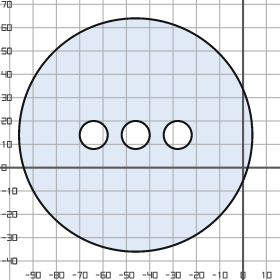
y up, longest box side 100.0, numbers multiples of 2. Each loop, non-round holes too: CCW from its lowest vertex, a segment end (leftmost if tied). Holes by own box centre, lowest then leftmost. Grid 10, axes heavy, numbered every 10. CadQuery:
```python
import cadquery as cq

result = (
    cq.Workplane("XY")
    .moveTo(-46.0, 14.0)
    .circle(50.0)
    .moveTo(-64.0, 14.0)
    .circle(6.0)
    .moveTo(-46.0, 14.0)
    .circle(6.0)
    .moveTo(-28.0, 14.0)
    .circle(6.0)
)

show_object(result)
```